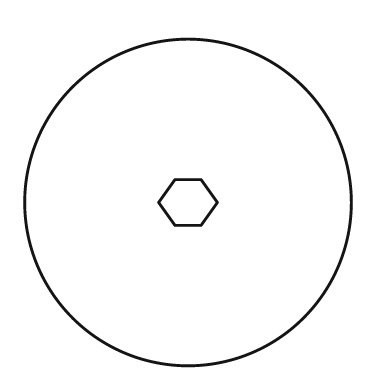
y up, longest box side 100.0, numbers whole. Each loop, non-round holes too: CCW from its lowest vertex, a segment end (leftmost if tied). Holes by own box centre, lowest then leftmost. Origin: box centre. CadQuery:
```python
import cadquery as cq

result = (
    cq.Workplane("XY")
    .moveTo(0.0, 0.0)
    .circle(50.0)
    .moveTo(-4.0, -7.0)
    .lineTo(4.0, -7.0)
    .lineTo(9.0, 0.0)
    .lineTo(4.0, 7.0)
    .lineTo(-4.0, 7.0)
    .lineTo(-9.0, 0.0)
    .close()
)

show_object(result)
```